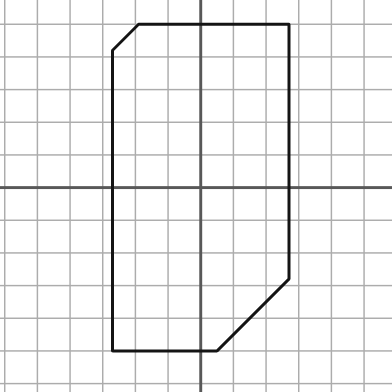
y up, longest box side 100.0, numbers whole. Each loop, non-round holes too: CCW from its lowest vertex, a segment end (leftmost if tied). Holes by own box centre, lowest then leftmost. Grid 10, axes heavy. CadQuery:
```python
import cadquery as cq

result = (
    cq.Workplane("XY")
    .moveTo(-27.0, -50.0)
    .lineTo(5.0, -50.0)
    .lineTo(27.0, -28.0)
    .lineTo(27.0, 50.0)
    .lineTo(-19.0, 50.0)
    .lineTo(-27.0, 42.0)
    .close()
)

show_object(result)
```